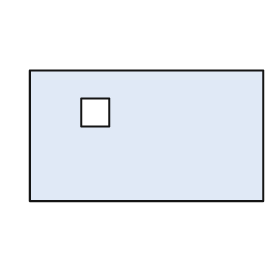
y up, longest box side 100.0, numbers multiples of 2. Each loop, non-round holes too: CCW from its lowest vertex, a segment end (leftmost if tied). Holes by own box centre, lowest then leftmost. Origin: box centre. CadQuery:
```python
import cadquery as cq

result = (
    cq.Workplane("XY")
    .moveTo(-50.0, -28.0)
    .lineTo(50.0, -28.0)
    .lineTo(50.0, 28.0)
    .lineTo(-50.0, 28.0)
    .close()
    .moveTo(-28.0, 4.0)
    .lineTo(-16.0, 4.0)
    .lineTo(-16.0, 16.0)
    .lineTo(-28.0, 16.0)
    .close()
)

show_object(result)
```